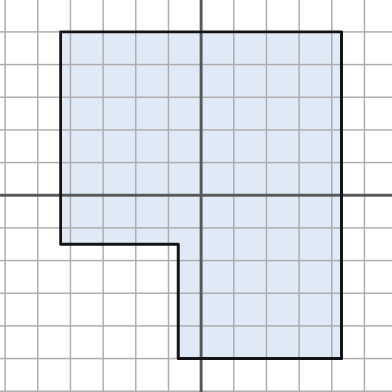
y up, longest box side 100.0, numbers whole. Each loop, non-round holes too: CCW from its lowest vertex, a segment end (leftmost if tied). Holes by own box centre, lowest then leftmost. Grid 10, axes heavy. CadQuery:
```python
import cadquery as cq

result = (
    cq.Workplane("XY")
    .moveTo(-7.0, -50.0)
    .lineTo(43.0, -50.0)
    .lineTo(43.0, 50.0)
    .lineTo(-43.0, 50.0)
    .lineTo(-43.0, -15.0)
    .lineTo(-7.0, -15.0)
    .close()
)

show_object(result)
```